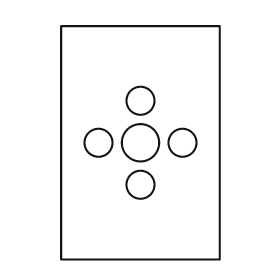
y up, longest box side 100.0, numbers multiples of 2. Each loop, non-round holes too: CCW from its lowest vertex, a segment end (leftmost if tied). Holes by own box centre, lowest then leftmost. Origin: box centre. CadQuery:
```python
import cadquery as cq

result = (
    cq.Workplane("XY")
    .moveTo(-34.0, -50.0)
    .lineTo(34.0, -50.0)
    .lineTo(34.0, 50.0)
    .lineTo(-34.0, 50.0)
    .close()
    .moveTo(0.0, -18.0)
    .circle(6.0)
    .moveTo(-18.0, 0.0)
    .circle(6.0)
    .moveTo(0.0, 0.0)
    .circle(8.0)
    .moveTo(18.0, 0.0)
    .circle(6.0)
    .moveTo(0.0, 18.0)
    .circle(6.0)
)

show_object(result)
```